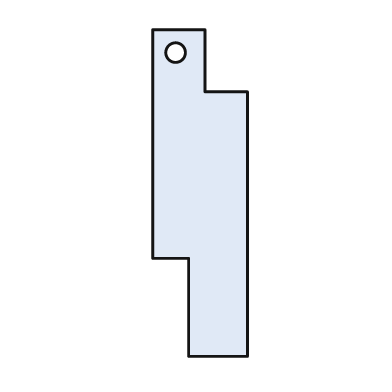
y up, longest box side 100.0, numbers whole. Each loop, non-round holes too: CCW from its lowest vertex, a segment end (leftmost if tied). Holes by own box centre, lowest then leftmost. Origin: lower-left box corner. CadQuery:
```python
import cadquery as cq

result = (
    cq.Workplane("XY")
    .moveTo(11.0, 0.0)
    .lineTo(29.0, 0.0)
    .lineTo(29.0, 81.0)
    .lineTo(16.0, 81.0)
    .lineTo(16.0, 100.0)
    .lineTo(0.0, 100.0)
    .lineTo(0.0, 30.0)
    .lineTo(11.0, 30.0)
    .close()
    .moveTo(7.0, 93.0)
    .circle(3.0)
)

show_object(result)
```